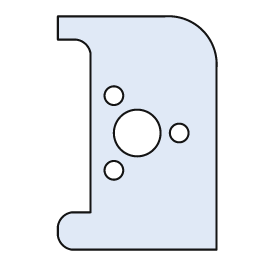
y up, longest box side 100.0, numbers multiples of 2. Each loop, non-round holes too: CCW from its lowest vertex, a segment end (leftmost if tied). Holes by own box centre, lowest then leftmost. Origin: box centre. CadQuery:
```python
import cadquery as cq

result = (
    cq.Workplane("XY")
    .moveTo(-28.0, -50.0)
    .lineTo(34.0, -50.0)
    .lineTo(34.0, 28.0)
    .threePointArc((28.0, 44.0), (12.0, 50.0))
    .lineTo(-34.0, 50.0)
    .lineTo(-34.0, 40.0)
    .lineTo(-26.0, 40.0)
    .threePointArc((-22.0, 38.0), (-20.0, 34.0))
    .lineTo(-20.0, -34.0)
    .lineTo(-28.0, -34.0)
    .threePointArc((-32.0, -36.0), (-34.0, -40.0))
    .lineTo(-34.0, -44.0)
    .threePointArc((-32.0, -48.0), (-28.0, -50.0))
    .close()
    .moveTo(-10.0, -16.0)
    .circle(4.0)
    .moveTo(0.0, 0.0)
    .circle(10.0)
    .moveTo(18.0, 0.0)
    .circle(4.0)
    .moveTo(-10.0, 16.0)
    .circle(4.0)
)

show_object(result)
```